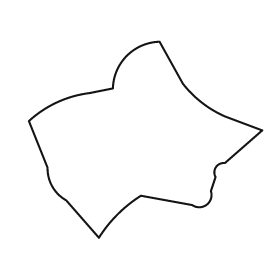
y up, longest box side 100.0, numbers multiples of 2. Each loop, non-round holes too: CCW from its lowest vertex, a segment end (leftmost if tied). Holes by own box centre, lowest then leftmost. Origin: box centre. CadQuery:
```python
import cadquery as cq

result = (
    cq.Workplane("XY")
    .moveTo(-20.0, -42.0)
    .threePointArc((-12.0, -32.0), (-2.0, -24.0))
    .lineTo(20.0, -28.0)
    .threePointArc((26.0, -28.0), (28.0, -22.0))
    .lineTo(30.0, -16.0)
    .threePointArc((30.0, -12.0), (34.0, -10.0))
    .lineTo(50.0, 4.0)
    .lineTo(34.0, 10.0)
    .threePointArc((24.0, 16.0), (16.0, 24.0))
    .lineTo(6.0, 42.0)
    .threePointArc((-8.0, 36.0), (-14.0, 22.0))
    .lineTo(-24.0, 20.0)
    .threePointArc((-38.0, 16.0), (-50.0, 8.0))
    .lineTo(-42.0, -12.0)
    .threePointArc((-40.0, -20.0), (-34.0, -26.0))
    .close()
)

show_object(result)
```